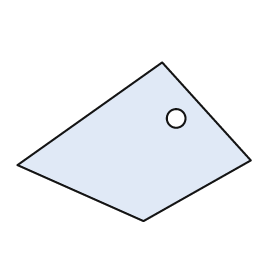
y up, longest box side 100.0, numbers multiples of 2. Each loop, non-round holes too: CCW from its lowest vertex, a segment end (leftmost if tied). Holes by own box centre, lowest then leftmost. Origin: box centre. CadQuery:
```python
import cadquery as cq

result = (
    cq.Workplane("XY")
    .moveTo(4.0, -34.0)
    .lineTo(50.0, -8.0)
    .lineTo(12.0, 34.0)
    .lineTo(-50.0, -10.0)
    .close()
    .moveTo(18.0, 10.0)
    .circle(4.0)
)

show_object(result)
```